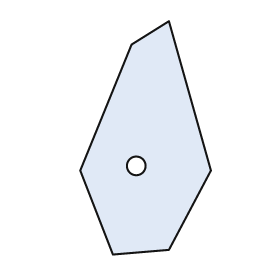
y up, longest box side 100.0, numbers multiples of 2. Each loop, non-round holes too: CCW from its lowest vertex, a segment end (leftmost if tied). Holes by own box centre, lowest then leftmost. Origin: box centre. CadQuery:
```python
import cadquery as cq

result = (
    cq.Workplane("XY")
    .moveTo(-14.0, -50.0)
    .lineTo(10.0, -48.0)
    .lineTo(28.0, -14.0)
    .lineTo(10.0, 50.0)
    .lineTo(-6.0, 40.0)
    .lineTo(-28.0, -14.0)
    .close()
    .moveTo(-4.0, -12.0)
    .circle(4.0)
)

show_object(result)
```